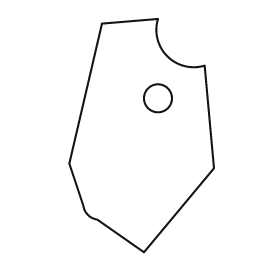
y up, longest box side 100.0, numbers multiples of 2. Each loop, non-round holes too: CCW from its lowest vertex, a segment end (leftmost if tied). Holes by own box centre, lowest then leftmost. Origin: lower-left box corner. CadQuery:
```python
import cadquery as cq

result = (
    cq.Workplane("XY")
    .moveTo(32.0, 0.0)
    .lineTo(62.0, 36.0)
    .lineTo(58.0, 80.0)
    .threePointArc((42.0, 84.0), (38.0, 100.0))
    .lineTo(14.0, 98.0)
    .lineTo(0.0, 38.0)
    .lineTo(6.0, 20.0)
    .threePointArc((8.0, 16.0), (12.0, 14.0))
    .close()
    .moveTo(38.0, 66.0)
    .circle(6.0)
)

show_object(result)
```